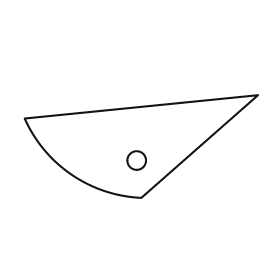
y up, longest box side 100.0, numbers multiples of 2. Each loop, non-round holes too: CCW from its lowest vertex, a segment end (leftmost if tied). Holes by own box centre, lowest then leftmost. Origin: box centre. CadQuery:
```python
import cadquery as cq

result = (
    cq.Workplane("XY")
    .moveTo(0.0, -22.0)
    .lineTo(50.0, 22.0)
    .lineTo(-50.0, 12.0)
    .threePointArc((-30.0, -12.0), (0.0, -22.0))
    .close()
    .moveTo(-2.0, -6.0)
    .circle(4.0)
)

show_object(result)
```